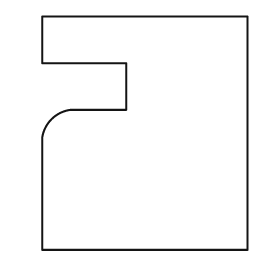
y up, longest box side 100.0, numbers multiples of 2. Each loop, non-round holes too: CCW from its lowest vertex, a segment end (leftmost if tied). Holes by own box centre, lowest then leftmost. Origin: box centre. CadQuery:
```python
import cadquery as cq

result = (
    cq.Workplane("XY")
    .moveTo(-44.0, -50.0)
    .lineTo(44.0, -50.0)
    .lineTo(44.0, 50.0)
    .lineTo(-44.0, 50.0)
    .lineTo(-44.0, 30.0)
    .lineTo(-8.0, 30.0)
    .lineTo(-8.0, 10.0)
    .lineTo(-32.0, 10.0)
    .threePointArc((-40.0, 6.0), (-44.0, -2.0))
    .close()
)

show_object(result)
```